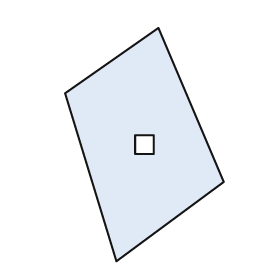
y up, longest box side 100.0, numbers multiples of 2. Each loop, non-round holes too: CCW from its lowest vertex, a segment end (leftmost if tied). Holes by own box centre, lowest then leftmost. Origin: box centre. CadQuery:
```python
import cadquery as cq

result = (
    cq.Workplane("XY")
    .moveTo(-12.0, -50.0)
    .lineTo(34.0, -16.0)
    .lineTo(6.0, 50.0)
    .lineTo(-34.0, 22.0)
    .close()
    .moveTo(-4.0, -4.0)
    .lineTo(4.0, -4.0)
    .lineTo(4.0, 4.0)
    .lineTo(-4.0, 4.0)
    .close()
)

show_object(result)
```